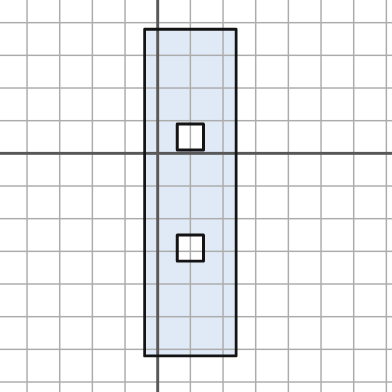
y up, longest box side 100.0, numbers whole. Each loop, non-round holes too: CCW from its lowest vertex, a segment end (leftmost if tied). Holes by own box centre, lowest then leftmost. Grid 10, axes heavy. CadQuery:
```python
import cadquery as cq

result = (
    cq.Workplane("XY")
    .moveTo(-4.0, -62.0)
    .lineTo(24.0, -62.0)
    .lineTo(24.0, 38.0)
    .lineTo(-4.0, 38.0)
    .close()
    .moveTo(6.0, -33.0)
    .lineTo(14.0, -33.0)
    .lineTo(14.0, -25.0)
    .lineTo(6.0, -25.0)
    .close()
    .moveTo(6.0, 1.0)
    .lineTo(14.0, 1.0)
    .lineTo(14.0, 9.0)
    .lineTo(6.0, 9.0)
    .close()
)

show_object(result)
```